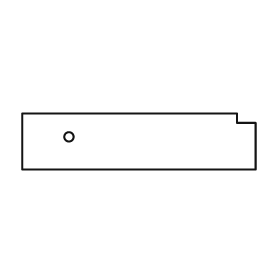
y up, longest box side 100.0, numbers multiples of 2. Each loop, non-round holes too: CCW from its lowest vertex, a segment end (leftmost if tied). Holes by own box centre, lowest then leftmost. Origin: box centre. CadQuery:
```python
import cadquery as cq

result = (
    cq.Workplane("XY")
    .moveTo(-50.0, -12.0)
    .lineTo(50.0, -12.0)
    .lineTo(50.0, 8.0)
    .lineTo(42.0, 8.0)
    .lineTo(42.0, 12.0)
    .lineTo(-50.0, 12.0)
    .close()
    .moveTo(-30.0, 2.0)
    .circle(2.0)
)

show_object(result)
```